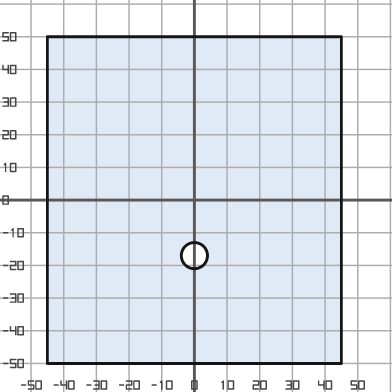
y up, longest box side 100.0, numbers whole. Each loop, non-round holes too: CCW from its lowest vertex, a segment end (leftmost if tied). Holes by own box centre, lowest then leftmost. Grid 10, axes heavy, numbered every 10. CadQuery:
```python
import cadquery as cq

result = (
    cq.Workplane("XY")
    .moveTo(-45.0, -50.0)
    .lineTo(45.0, -50.0)
    .lineTo(45.0, 50.0)
    .lineTo(-45.0, 50.0)
    .close()
    .moveTo(0.0, -17.0)
    .circle(4.0)
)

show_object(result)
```